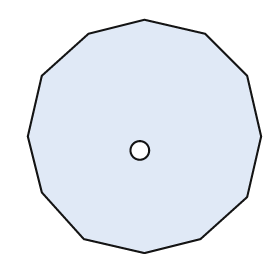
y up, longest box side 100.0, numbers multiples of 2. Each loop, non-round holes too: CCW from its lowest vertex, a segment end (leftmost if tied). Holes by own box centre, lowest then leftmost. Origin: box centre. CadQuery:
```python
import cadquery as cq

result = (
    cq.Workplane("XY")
    .moveTo(0.0, -50.0)
    .lineTo(24.0, -44.0)
    .lineTo(44.0, -26.0)
    .lineTo(50.0, 0.0)
    .lineTo(44.0, 26.0)
    .lineTo(26.0, 44.0)
    .lineTo(0.0, 50.0)
    .lineTo(-24.0, 44.0)
    .lineTo(-44.0, 26.0)
    .lineTo(-50.0, 0.0)
    .lineTo(-44.0, -24.0)
    .lineTo(-26.0, -44.0)
    .close()
    .moveTo(-2.0, -6.0)
    .circle(4.0)
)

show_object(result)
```